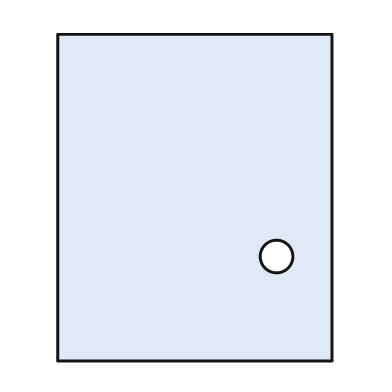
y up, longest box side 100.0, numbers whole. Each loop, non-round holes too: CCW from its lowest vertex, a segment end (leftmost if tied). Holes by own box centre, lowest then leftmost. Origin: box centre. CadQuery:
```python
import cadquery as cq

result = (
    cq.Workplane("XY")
    .moveTo(-42.0, -50.0)
    .lineTo(42.0, -50.0)
    .lineTo(42.0, 50.0)
    .lineTo(-42.0, 50.0)
    .close()
    .moveTo(25.0, -18.0)
    .circle(5.0)
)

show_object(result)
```